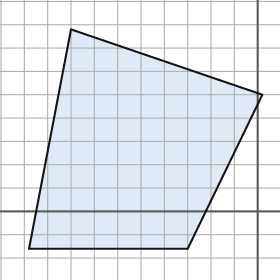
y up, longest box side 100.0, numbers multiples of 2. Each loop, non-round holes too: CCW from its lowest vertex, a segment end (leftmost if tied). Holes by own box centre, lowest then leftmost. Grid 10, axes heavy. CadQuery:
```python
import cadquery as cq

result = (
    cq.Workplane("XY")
    .moveTo(-98.0, -16.0)
    .lineTo(-30.0, -16.0)
    .lineTo(2.0, 50.0)
    .lineTo(-80.0, 78.0)
    .close()
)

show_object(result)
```